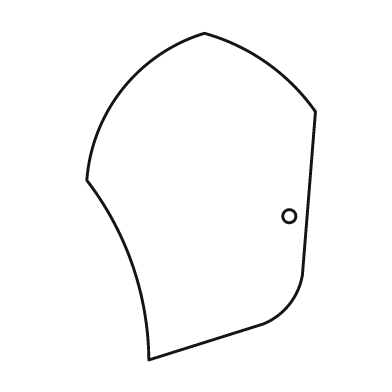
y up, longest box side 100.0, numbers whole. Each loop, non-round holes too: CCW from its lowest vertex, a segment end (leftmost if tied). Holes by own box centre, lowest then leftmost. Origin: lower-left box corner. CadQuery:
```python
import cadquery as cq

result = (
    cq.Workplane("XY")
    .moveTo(19.0, 0.0)
    .lineTo(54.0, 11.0)
    .threePointArc((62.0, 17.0), (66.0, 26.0))
    .lineTo(70.0, 76.0)
    .threePointArc((55.0, 91.0), (36.0, 100.0))
    .threePointArc((11.0, 83.0), (0.0, 55.0))
    .threePointArc((14.0, 29.0), (19.0, 0.0))
    .close()
    .moveTo(62.0, 44.0)
    .circle(2.0)
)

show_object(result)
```